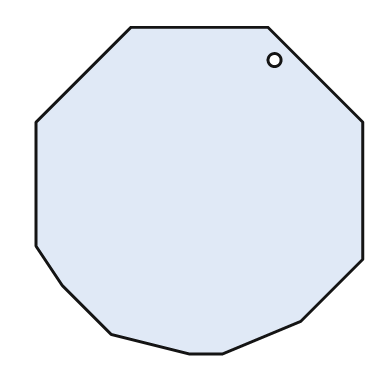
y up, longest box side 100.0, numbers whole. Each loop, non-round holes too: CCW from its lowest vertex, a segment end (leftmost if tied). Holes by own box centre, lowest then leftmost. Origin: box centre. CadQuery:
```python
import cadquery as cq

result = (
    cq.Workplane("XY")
    .moveTo(-3.0, -50.0)
    .lineTo(7.0, -50.0)
    .lineTo(31.0, -40.0)
    .lineTo(50.0, -21.0)
    .lineTo(50.0, 21.0)
    .lineTo(21.0, 50.0)
    .lineTo(-21.0, 50.0)
    .lineTo(-50.0, 21.0)
    .lineTo(-50.0, -17.0)
    .lineTo(-42.0, -29.0)
    .lineTo(-27.0, -44.0)
    .close()
    .moveTo(23.0, 40.0)
    .circle(2.0)
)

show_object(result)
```